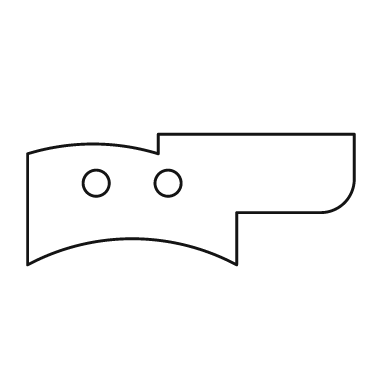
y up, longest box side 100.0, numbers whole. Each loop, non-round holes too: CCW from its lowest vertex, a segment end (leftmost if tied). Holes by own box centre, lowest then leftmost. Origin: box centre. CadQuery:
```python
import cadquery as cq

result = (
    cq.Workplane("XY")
    .moveTo(-50.0, -20.0)
    .threePointArc((-18.0, -12.0), (14.0, -20.0))
    .lineTo(14.0, -4.0)
    .lineTo(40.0, -4.0)
    .threePointArc((47.0, -1.0), (50.0, 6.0))
    .lineTo(50.0, 20.0)
    .lineTo(-10.0, 20.0)
    .lineTo(-10.0, 14.0)
    .threePointArc((-30.0, 17.0), (-50.0, 14.0))
    .close()
    .moveTo(-29.0, 5.0)
    .circle(4.0)
    .moveTo(-7.0, 5.0)
    .circle(4.0)
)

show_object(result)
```